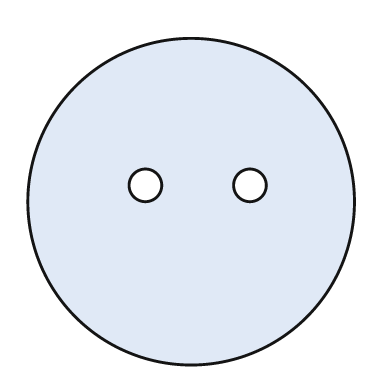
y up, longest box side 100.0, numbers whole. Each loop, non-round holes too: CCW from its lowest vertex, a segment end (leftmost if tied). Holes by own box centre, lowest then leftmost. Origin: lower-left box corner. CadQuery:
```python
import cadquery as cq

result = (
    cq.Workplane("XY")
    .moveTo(50.0, 50.0)
    .circle(50.0)
    .moveTo(36.0, 55.0)
    .circle(5.0)
    .moveTo(68.0, 55.0)
    .circle(5.0)
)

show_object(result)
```